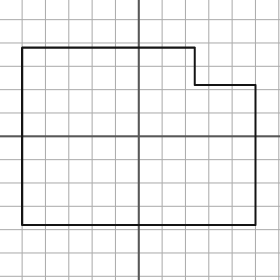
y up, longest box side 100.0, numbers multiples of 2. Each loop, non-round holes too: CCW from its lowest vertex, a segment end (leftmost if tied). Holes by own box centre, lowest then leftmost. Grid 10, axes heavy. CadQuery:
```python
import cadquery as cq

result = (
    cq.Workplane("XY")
    .moveTo(-50.0, -38.0)
    .lineTo(50.0, -38.0)
    .lineTo(50.0, 22.0)
    .lineTo(24.0, 22.0)
    .lineTo(24.0, 38.0)
    .lineTo(-50.0, 38.0)
    .close()
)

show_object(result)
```